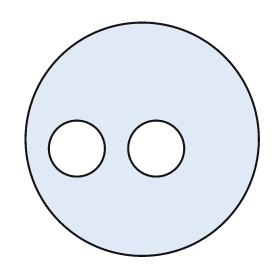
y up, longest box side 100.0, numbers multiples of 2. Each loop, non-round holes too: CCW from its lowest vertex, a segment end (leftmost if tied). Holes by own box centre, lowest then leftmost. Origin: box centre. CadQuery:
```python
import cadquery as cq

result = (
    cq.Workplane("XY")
    .moveTo(0.0, 0.0)
    .circle(50.0)
    .moveTo(-28.0, -4.0)
    .circle(12.0)
    .moveTo(6.0, -4.0)
    .circle(12.0)
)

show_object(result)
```